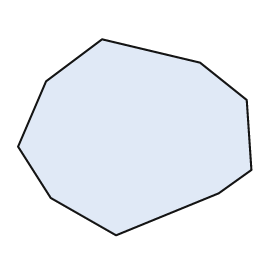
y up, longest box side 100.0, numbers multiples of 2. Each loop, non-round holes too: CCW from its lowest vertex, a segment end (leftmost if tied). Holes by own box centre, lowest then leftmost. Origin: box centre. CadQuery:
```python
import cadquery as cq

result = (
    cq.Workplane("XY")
    .moveTo(-8.0, -42.0)
    .lineTo(36.0, -24.0)
    .lineTo(50.0, -14.0)
    .lineTo(48.0, 16.0)
    .lineTo(28.0, 32.0)
    .lineTo(-14.0, 42.0)
    .lineTo(-38.0, 24.0)
    .lineTo(-50.0, -4.0)
    .lineTo(-36.0, -26.0)
    .close()
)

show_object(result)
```